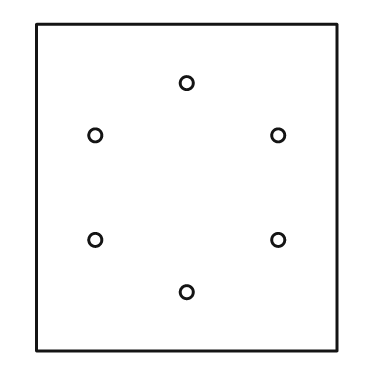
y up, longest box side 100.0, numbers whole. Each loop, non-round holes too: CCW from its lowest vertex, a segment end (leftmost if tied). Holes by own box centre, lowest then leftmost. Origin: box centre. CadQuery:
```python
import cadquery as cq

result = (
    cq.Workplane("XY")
    .moveTo(-46.0, -50.0)
    .lineTo(46.0, -50.0)
    .lineTo(46.0, 50.0)
    .lineTo(-46.0, 50.0)
    .close()
    .moveTo(0.0, -32.0)
    .circle(2.0)
    .moveTo(-28.0, -16.0)
    .circle(2.0)
    .moveTo(28.0, -16.0)
    .circle(2.0)
    .moveTo(-28.0, 16.0)
    .circle(2.0)
    .moveTo(28.0, 16.0)
    .circle(2.0)
    .moveTo(0.0, 32.0)
    .circle(2.0)
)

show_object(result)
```